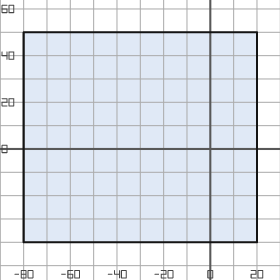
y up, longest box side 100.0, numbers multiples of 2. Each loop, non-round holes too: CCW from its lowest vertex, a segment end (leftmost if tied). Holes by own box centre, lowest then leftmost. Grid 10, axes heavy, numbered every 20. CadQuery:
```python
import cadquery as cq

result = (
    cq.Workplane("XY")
    .moveTo(-80.0, -40.0)
    .lineTo(20.0, -40.0)
    .lineTo(20.0, 50.0)
    .lineTo(-80.0, 50.0)
    .close()
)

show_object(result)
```